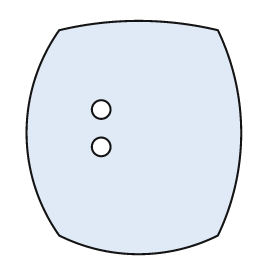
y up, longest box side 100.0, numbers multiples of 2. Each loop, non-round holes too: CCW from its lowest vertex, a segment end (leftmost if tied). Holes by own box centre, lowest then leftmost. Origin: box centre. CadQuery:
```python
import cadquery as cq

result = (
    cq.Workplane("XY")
    .moveTo(-32.0, -42.0)
    .threePointArc((2.0, -50.0), (36.0, -42.0))
    .threePointArc((46.0, 2.0), (36.0, 46.0))
    .threePointArc((2.0, 50.0), (-32.0, 46.0))
    .threePointArc((-46.0, 2.0), (-32.0, -42.0))
    .close()
    .moveTo(-14.0, -4.0)
    .circle(4.0)
    .moveTo(-14.0, 12.0)
    .circle(4.0)
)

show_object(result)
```